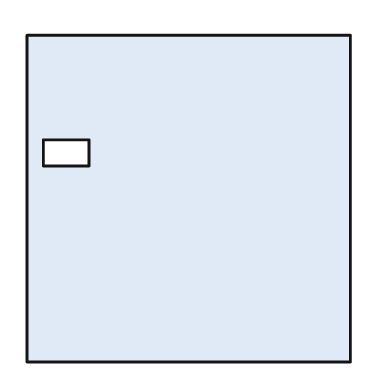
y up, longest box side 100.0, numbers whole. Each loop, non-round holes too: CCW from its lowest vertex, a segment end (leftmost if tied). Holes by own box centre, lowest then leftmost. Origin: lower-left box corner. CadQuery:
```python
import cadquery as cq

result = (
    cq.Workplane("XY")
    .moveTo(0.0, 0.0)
    .lineTo(99.0, 0.0)
    .lineTo(99.0, 100.0)
    .lineTo(0.0, 100.0)
    .close()
    .moveTo(5.0, 60.0)
    .lineTo(19.0, 60.0)
    .lineTo(19.0, 68.0)
    .lineTo(5.0, 68.0)
    .close()
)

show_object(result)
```